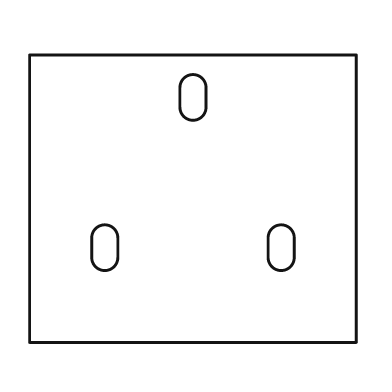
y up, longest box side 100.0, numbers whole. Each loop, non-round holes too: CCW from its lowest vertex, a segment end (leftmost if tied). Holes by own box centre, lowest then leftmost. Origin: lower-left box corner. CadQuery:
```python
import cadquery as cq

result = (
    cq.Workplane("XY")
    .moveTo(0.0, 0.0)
    .lineTo(100.0, 0.0)
    .lineTo(100.0, 88.0)
    .lineTo(0.0, 88.0)
    .close()
    .moveTo(19.0, 26.0)
    .threePointArc((23.0, 22.0), (27.0, 26.0))
    .lineTo(27.0, 32.0)
    .threePointArc((23.0, 36.0), (19.0, 32.0))
    .close()
    .moveTo(73.0, 26.0)
    .threePointArc((77.0, 22.0), (81.0, 26.0))
    .lineTo(81.0, 32.0)
    .threePointArc((77.0, 36.0), (73.0, 32.0))
    .close()
    .moveTo(46.0, 72.0)
    .threePointArc((50.0, 68.0), (54.0, 72.0))
    .lineTo(54.0, 78.0)
    .threePointArc((50.0, 82.0), (46.0, 78.0))
    .close()
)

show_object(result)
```